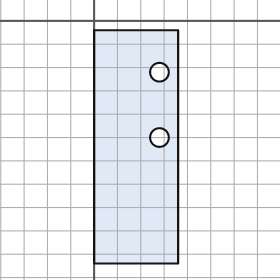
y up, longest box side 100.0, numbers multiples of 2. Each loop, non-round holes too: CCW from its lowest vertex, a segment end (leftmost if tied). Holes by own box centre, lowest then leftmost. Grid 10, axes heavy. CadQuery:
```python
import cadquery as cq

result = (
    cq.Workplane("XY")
    .moveTo(0.0, -104.0)
    .lineTo(36.0, -104.0)
    .lineTo(36.0, -4.0)
    .lineTo(0.0, -4.0)
    .close()
    .moveTo(28.0, -50.0)
    .circle(4.0)
    .moveTo(28.0, -22.0)
    .circle(4.0)
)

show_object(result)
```